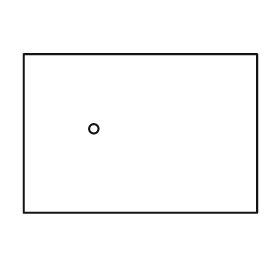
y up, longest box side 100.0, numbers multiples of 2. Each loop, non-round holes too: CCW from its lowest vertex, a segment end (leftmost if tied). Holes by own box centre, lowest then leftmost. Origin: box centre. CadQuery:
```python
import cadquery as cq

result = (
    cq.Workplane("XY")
    .moveTo(-50.0, -34.0)
    .lineTo(50.0, -34.0)
    .lineTo(50.0, 34.0)
    .lineTo(-50.0, 34.0)
    .close()
    .moveTo(-20.0, 2.0)
    .circle(2.0)
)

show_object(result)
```